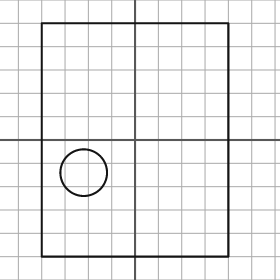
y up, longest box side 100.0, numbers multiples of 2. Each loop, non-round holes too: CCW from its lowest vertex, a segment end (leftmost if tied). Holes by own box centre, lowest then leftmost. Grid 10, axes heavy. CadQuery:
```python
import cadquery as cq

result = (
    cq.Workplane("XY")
    .moveTo(-40.0, -50.0)
    .lineTo(40.0, -50.0)
    .lineTo(40.0, 50.0)
    .lineTo(-40.0, 50.0)
    .close()
    .moveTo(-22.0, -14.0)
    .circle(10.0)
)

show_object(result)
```